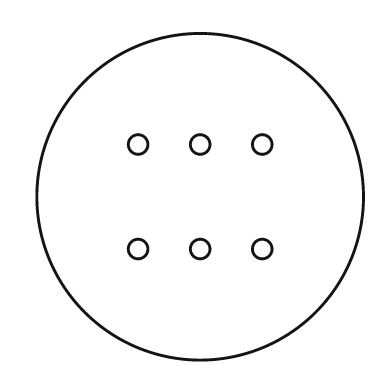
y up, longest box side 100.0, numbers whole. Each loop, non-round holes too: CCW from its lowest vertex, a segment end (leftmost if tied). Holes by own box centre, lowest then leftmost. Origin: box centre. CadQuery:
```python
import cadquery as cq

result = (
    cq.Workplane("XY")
    .moveTo(0.0, 0.0)
    .circle(50.0)
    .moveTo(-19.0, -16.0)
    .circle(3.0)
    .moveTo(0.0, -16.0)
    .circle(3.0)
    .moveTo(19.0, -16.0)
    .circle(3.0)
    .moveTo(-19.0, 16.0)
    .circle(3.0)
    .moveTo(0.0, 16.0)
    .circle(3.0)
    .moveTo(19.0, 16.0)
    .circle(3.0)
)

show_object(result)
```